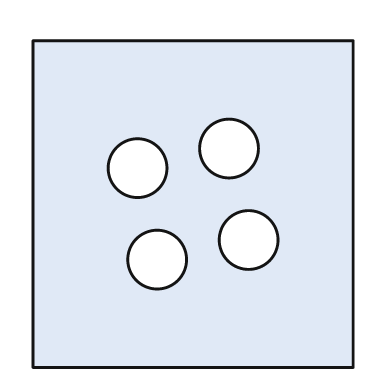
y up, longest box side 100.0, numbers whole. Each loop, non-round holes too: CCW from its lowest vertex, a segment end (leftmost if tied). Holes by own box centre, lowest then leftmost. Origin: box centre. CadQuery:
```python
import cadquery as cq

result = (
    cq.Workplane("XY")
    .moveTo(-49.0, -50.0)
    .lineTo(49.0, -50.0)
    .lineTo(49.0, 50.0)
    .lineTo(-49.0, 50.0)
    .close()
    .moveTo(-11.0, -17.0)
    .circle(9.0)
    .moveTo(17.0, -11.0)
    .circle(9.0)
    .moveTo(-17.0, 11.0)
    .circle(9.0)
    .moveTo(11.0, 17.0)
    .circle(9.0)
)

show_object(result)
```